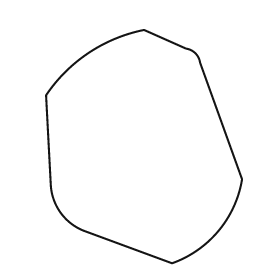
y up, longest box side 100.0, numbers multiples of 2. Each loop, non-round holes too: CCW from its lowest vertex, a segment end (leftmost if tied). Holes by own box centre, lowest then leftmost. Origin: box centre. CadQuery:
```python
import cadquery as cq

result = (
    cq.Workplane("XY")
    .moveTo(12.0, -50.0)
    .threePointArc((32.0, -36.0), (42.0, -14.0))
    .lineTo(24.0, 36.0)
    .threePointArc((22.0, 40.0), (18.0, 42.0))
    .lineTo(0.0, 50.0)
    .threePointArc((-24.0, 40.0), (-42.0, 22.0))
    .lineTo(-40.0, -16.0)
    .threePointArc((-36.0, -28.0), (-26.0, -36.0))
    .close()
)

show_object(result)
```